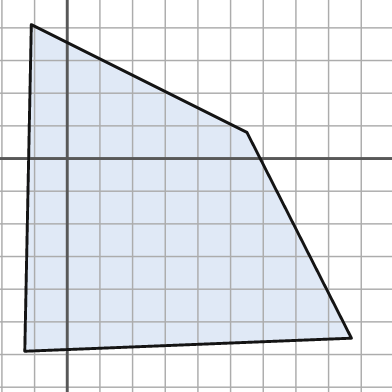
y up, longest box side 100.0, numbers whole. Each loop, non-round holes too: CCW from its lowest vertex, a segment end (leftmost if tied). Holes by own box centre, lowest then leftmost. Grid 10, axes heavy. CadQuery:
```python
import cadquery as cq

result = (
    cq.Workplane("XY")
    .moveTo(-13.0, -59.0)
    .lineTo(87.0, -55.0)
    .lineTo(55.0, 8.0)
    .lineTo(-11.0, 41.0)
    .close()
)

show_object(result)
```